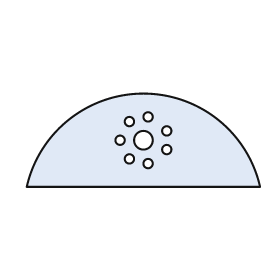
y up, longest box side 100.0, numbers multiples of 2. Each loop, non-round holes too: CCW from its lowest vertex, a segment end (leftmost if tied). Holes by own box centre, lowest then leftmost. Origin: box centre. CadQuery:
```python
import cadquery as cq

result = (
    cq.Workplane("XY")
    .moveTo(-50.0, -20.0)
    .lineTo(50.0, -20.0)
    .threePointArc((0.0, 20.0), (-50.0, -20.0))
    .close()
    .moveTo(2.0, -10.0)
    .circle(2.0)
    .moveTo(-6.0, -8.0)
    .circle(2.0)
    .moveTo(10.0, -4.0)
    .circle(2.0)
    .moveTo(-10.0, 0.0)
    .circle(2.0)
    .moveTo(0.0, 0.0)
    .circle(4.0)
    .moveTo(10.0, 4.0)
    .circle(2.0)
    .moveTo(-6.0, 8.0)
    .circle(2.0)
    .moveTo(2.0, 10.0)
    .circle(2.0)
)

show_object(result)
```